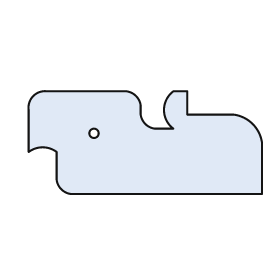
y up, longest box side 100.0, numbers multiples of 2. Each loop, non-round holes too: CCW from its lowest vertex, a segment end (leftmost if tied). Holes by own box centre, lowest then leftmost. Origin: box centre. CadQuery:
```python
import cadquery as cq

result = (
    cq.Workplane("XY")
    .moveTo(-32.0, -22.0)
    .lineTo(50.0, -22.0)
    .lineTo(50.0, 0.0)
    .threePointArc((46.0, 8.0), (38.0, 12.0))
    .lineTo(18.0, 12.0)
    .lineTo(18.0, 22.0)
    .lineTo(12.0, 22.0)
    .threePointArc((8.0, 14.0), (12.0, 6.0))
    .lineTo(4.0, 6.0)
    .threePointArc((0.0, 8.0), (-2.0, 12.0))
    .lineTo(-2.0, 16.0)
    .threePointArc((-4.0, 20.0), (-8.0, 22.0))
    .lineTo(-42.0, 22.0)
    .threePointArc((-48.0, 20.0), (-50.0, 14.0))
    .lineTo(-50.0, -4.0)
    .threePointArc((-44.0, -2.0), (-38.0, -4.0))
    .lineTo(-38.0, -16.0)
    .threePointArc((-36.0, -20.0), (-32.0, -22.0))
    .close()
    .moveTo(-22.0, 4.0)
    .circle(2.0)
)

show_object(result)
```